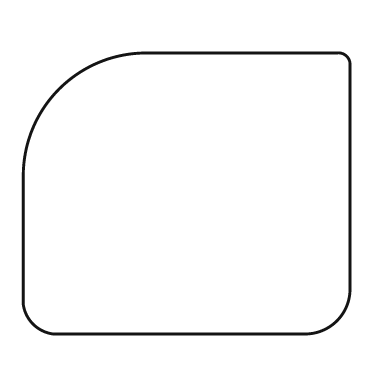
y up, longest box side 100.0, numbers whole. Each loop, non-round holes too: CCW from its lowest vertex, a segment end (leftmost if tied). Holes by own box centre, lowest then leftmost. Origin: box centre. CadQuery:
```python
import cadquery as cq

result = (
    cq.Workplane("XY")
    .moveTo(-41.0, -43.0)
    .lineTo(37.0, -43.0)
    .threePointArc((46.0, -39.0), (50.0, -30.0))
    .lineTo(50.0, 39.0)
    .threePointArc((49.0, 42.0), (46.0, 43.0))
    .lineTo(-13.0, 43.0)
    .threePointArc((-39.0, 32.0), (-50.0, 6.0))
    .lineTo(-50.0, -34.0)
    .threePointArc((-47.0, -40.0), (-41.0, -43.0))
    .close()
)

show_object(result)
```